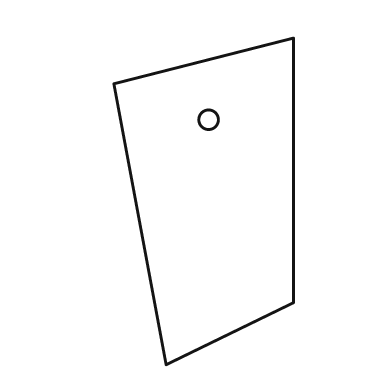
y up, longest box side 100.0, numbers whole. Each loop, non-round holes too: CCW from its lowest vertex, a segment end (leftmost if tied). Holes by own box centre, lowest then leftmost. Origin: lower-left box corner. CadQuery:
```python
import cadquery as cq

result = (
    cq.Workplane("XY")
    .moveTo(16.0, 0.0)
    .lineTo(55.0, 19.0)
    .lineTo(55.0, 100.0)
    .lineTo(0.0, 86.0)
    .close()
    .moveTo(29.0, 75.0)
    .circle(3.0)
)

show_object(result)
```